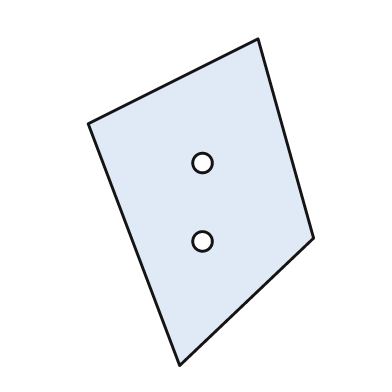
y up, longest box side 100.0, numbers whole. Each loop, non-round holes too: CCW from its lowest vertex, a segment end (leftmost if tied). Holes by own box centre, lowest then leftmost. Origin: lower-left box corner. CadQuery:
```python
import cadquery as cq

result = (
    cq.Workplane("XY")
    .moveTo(28.0, 0.0)
    .lineTo(69.0, 39.0)
    .lineTo(52.0, 100.0)
    .lineTo(0.0, 74.0)
    .close()
    .moveTo(35.0, 38.0)
    .circle(3.0)
    .moveTo(35.0, 62.0)
    .circle(3.0)
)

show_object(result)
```